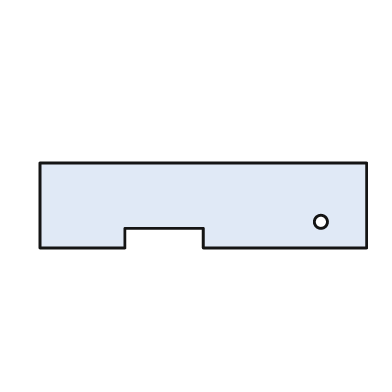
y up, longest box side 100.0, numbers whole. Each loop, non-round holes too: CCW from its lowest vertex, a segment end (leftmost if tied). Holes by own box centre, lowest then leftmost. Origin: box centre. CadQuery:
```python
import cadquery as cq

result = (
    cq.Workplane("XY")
    .moveTo(-50.0, -13.0)
    .lineTo(-24.0, -13.0)
    .lineTo(-24.0, -7.0)
    .lineTo(0.0, -7.0)
    .lineTo(0.0, -13.0)
    .lineTo(50.0, -13.0)
    .lineTo(50.0, 13.0)
    .lineTo(-50.0, 13.0)
    .close()
    .moveTo(36.0, -5.0)
    .circle(2.0)
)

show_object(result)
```